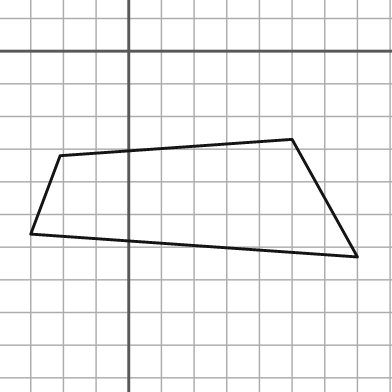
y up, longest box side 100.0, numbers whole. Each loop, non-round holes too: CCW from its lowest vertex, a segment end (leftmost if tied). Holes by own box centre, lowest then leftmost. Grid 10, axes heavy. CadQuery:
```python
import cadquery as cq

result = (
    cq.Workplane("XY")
    .moveTo(70.0, -63.0)
    .lineTo(50.0, -27.0)
    .lineTo(-21.0, -32.0)
    .lineTo(-30.0, -56.0)
    .close()
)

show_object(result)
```